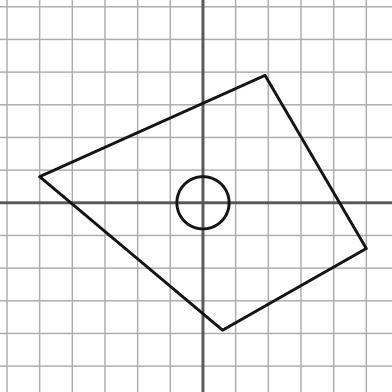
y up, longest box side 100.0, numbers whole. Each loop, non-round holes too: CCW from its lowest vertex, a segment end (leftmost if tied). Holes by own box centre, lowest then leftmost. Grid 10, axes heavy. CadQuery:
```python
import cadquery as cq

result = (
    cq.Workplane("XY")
    .moveTo(6.0, -39.0)
    .lineTo(50.0, -14.0)
    .lineTo(19.0, 39.0)
    .lineTo(-50.0, 8.0)
    .close()
    .moveTo(0.0, 0.0)
    .circle(8.0)
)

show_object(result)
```